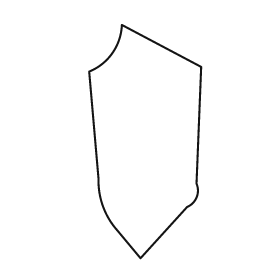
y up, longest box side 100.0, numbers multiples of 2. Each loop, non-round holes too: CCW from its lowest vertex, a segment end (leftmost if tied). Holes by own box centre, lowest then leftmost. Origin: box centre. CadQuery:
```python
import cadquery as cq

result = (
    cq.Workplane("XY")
    .moveTo(-2.0, -50.0)
    .lineTo(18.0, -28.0)
    .threePointArc((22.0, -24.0), (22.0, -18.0))
    .lineTo(24.0, 32.0)
    .lineTo(-10.0, 50.0)
    .threePointArc((-14.0, 38.0), (-24.0, 30.0))
    .lineTo(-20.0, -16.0)
    .threePointArc((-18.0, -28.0), (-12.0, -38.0))
    .close()
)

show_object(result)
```